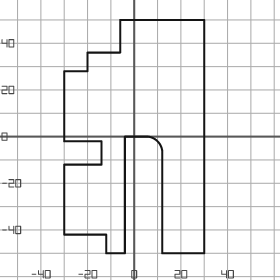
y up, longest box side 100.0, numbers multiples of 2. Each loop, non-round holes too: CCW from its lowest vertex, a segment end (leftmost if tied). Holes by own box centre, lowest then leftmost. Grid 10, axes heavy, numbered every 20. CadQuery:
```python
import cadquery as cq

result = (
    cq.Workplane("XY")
    .moveTo(-12.0, -50.0)
    .lineTo(-4.0, -50.0)
    .lineTo(-4.0, 0.0)
    .lineTo(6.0, 0.0)
    .threePointArc((10.0, -2.0), (12.0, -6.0))
    .lineTo(12.0, -50.0)
    .lineTo(30.0, -50.0)
    .lineTo(30.0, 50.0)
    .lineTo(-6.0, 50.0)
    .lineTo(-6.0, 36.0)
    .lineTo(-20.0, 36.0)
    .lineTo(-20.0, 28.0)
    .lineTo(-30.0, 28.0)
    .lineTo(-30.0, -2.0)
    .lineTo(-14.0, -2.0)
    .lineTo(-14.0, -12.0)
    .lineTo(-30.0, -12.0)
    .lineTo(-30.0, -42.0)
    .lineTo(-12.0, -42.0)
    .close()
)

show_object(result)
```